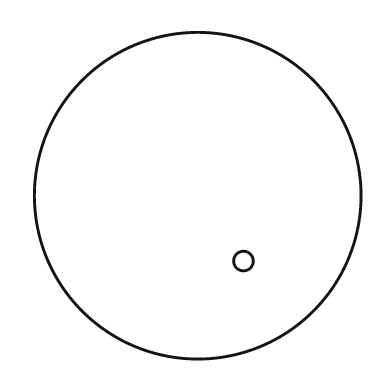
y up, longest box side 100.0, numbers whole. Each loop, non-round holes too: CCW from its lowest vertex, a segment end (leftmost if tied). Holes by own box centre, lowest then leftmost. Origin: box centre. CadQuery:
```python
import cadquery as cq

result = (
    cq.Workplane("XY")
    .moveTo(0.0, 0.0)
    .circle(50.0)
    .moveTo(14.0, -20.0)
    .circle(3.0)
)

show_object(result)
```